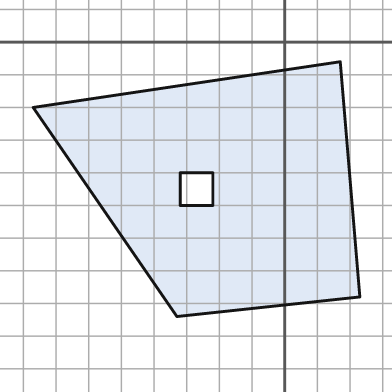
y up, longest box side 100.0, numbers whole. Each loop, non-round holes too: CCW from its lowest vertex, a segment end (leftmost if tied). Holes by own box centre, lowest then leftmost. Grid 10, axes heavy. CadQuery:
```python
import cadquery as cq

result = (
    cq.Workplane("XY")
    .moveTo(-33.0, -84.0)
    .lineTo(23.0, -78.0)
    .lineTo(17.0, -6.0)
    .lineTo(-77.0, -20.0)
    .close()
    .moveTo(-32.0, -50.0)
    .lineTo(-22.0, -50.0)
    .lineTo(-22.0, -40.0)
    .lineTo(-32.0, -40.0)
    .close()
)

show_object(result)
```